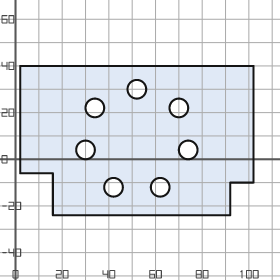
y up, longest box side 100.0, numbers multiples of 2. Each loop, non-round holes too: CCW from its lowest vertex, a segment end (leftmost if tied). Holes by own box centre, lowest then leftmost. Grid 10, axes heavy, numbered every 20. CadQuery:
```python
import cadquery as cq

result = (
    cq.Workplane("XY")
    .moveTo(16.0, -24.0)
    .lineTo(92.0, -24.0)
    .lineTo(92.0, -10.0)
    .lineTo(102.0, -10.0)
    .lineTo(102.0, 40.0)
    .lineTo(2.0, 40.0)
    .lineTo(2.0, -6.0)
    .lineTo(16.0, -6.0)
    .close()
    .moveTo(42.0, -12.0)
    .circle(4.0)
    .moveTo(62.0, -12.0)
    .circle(4.0)
    .moveTo(30.0, 4.0)
    .circle(4.0)
    .moveTo(74.0, 4.0)
    .circle(4.0)
    .moveTo(34.0, 22.0)
    .circle(4.0)
    .moveTo(70.0, 22.0)
    .circle(4.0)
    .moveTo(52.0, 30.0)
    .circle(4.0)
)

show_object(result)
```